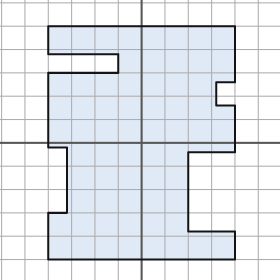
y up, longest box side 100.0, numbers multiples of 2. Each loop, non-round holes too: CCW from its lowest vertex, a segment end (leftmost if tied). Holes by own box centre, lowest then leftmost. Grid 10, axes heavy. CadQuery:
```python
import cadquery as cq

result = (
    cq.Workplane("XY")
    .moveTo(-40.0, -50.0)
    .lineTo(40.0, -50.0)
    .lineTo(40.0, -38.0)
    .lineTo(20.0, -38.0)
    .lineTo(20.0, -4.0)
    .lineTo(40.0, -4.0)
    .lineTo(40.0, 16.0)
    .lineTo(32.0, 16.0)
    .lineTo(32.0, 26.0)
    .lineTo(40.0, 26.0)
    .lineTo(40.0, 50.0)
    .lineTo(-40.0, 50.0)
    .lineTo(-40.0, 38.0)
    .lineTo(-10.0, 38.0)
    .lineTo(-10.0, 30.0)
    .lineTo(-40.0, 30.0)
    .lineTo(-40.0, -2.0)
    .lineTo(-32.0, -2.0)
    .lineTo(-32.0, -30.0)
    .lineTo(-40.0, -30.0)
    .close()
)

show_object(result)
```